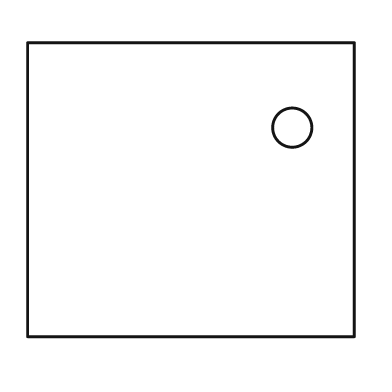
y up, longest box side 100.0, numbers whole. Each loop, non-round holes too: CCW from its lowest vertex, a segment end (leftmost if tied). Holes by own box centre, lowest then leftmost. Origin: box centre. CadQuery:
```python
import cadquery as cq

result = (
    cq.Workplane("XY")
    .moveTo(-50.0, -45.0)
    .lineTo(50.0, -45.0)
    .lineTo(50.0, 45.0)
    .lineTo(-50.0, 45.0)
    .close()
    .moveTo(31.0, 19.0)
    .circle(6.0)
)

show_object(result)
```